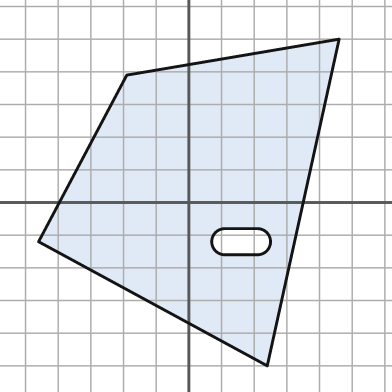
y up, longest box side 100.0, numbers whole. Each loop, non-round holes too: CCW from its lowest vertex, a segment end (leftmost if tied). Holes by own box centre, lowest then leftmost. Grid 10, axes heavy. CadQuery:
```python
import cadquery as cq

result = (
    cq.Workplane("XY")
    .moveTo(24.0, -50.0)
    .lineTo(46.0, 50.0)
    .lineTo(-19.0, 39.0)
    .lineTo(-46.0, -12.0)
    .close()
    .moveTo(11.0, -16.0)
    .lineTo(21.0, -16.0)
    .threePointArc((25.0, -12.0), (21.0, -8.0))
    .lineTo(11.0, -8.0)
    .threePointArc((7.0, -12.0), (11.0, -16.0))
    .close()
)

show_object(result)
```